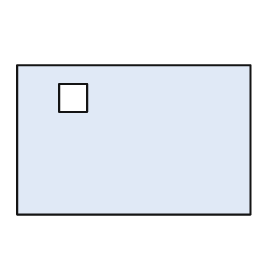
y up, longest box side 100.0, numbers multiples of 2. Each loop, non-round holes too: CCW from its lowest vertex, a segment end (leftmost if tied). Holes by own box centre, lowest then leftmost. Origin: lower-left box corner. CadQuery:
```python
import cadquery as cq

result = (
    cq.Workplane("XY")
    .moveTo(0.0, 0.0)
    .lineTo(100.0, 0.0)
    .lineTo(100.0, 64.0)
    .lineTo(0.0, 64.0)
    .close()
    .moveTo(18.0, 44.0)
    .lineTo(30.0, 44.0)
    .lineTo(30.0, 56.0)
    .lineTo(18.0, 56.0)
    .close()
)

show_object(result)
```